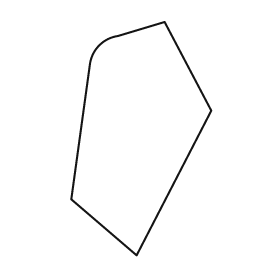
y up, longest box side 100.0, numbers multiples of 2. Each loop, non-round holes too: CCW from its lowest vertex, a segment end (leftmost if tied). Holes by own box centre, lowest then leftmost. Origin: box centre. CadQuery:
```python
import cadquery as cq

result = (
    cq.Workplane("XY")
    .moveTo(-2.0, -50.0)
    .lineTo(30.0, 12.0)
    .lineTo(10.0, 50.0)
    .lineTo(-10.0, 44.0)
    .threePointArc((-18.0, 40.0), (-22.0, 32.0))
    .lineTo(-30.0, -26.0)
    .close()
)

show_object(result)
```